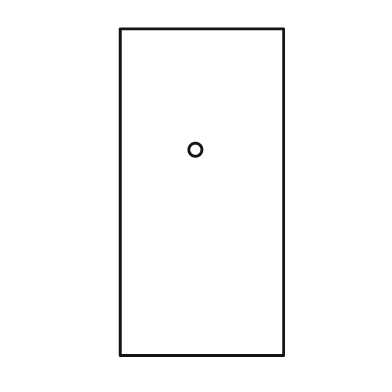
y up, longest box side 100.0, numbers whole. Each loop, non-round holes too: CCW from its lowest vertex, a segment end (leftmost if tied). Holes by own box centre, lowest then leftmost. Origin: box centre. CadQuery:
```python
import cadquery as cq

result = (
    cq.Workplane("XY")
    .moveTo(-25.0, -50.0)
    .lineTo(25.0, -50.0)
    .lineTo(25.0, 50.0)
    .lineTo(-25.0, 50.0)
    .close()
    .moveTo(-2.0, 13.0)
    .circle(2.0)
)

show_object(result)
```